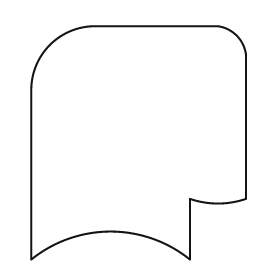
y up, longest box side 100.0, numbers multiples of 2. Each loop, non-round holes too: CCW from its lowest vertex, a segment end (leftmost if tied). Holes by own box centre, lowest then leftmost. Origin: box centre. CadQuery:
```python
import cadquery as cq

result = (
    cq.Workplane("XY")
    .moveTo(-46.0, -50.0)
    .threePointArc((-12.0, -38.0), (22.0, -50.0))
    .lineTo(22.0, -24.0)
    .threePointArc((34.0, -26.0), (46.0, -24.0))
    .lineTo(46.0, 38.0)
    .threePointArc((42.0, 46.0), (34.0, 50.0))
    .lineTo(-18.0, 50.0)
    .threePointArc((-38.0, 42.0), (-46.0, 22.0))
    .close()
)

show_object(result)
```